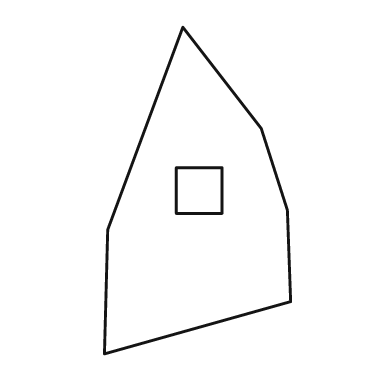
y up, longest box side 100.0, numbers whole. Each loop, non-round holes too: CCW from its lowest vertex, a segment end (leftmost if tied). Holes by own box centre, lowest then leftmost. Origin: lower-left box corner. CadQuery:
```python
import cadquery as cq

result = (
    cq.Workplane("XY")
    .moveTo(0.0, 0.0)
    .lineTo(57.0, 16.0)
    .lineTo(56.0, 44.0)
    .lineTo(48.0, 69.0)
    .lineTo(24.0, 100.0)
    .lineTo(1.0, 38.0)
    .close()
    .moveTo(22.0, 43.0)
    .lineTo(36.0, 43.0)
    .lineTo(36.0, 57.0)
    .lineTo(22.0, 57.0)
    .close()
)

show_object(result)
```